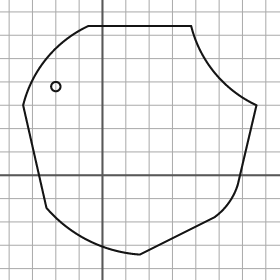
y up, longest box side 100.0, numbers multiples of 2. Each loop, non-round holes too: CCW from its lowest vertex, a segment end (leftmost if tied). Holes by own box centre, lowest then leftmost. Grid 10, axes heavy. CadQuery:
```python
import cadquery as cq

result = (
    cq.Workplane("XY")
    .moveTo(16.0, -34.0)
    .lineTo(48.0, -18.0)
    .threePointArc((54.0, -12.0), (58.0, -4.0))
    .lineTo(66.0, 30.0)
    .threePointArc((48.0, 44.0), (38.0, 64.0))
    .lineTo(-6.0, 64.0)
    .threePointArc((-24.0, 50.0), (-34.0, 30.0))
    .lineTo(-24.0, -14.0)
    .threePointArc((-6.0, -28.0), (16.0, -34.0))
    .close()
    .moveTo(-20.0, 38.0)
    .circle(2.0)
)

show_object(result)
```